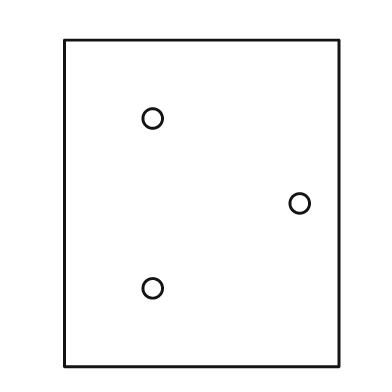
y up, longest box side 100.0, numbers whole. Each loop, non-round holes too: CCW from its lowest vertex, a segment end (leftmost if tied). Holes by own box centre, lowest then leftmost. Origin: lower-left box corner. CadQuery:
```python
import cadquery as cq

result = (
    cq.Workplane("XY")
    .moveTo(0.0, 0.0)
    .lineTo(84.0, 0.0)
    .lineTo(84.0, 100.0)
    .lineTo(0.0, 100.0)
    .close()
    .moveTo(27.0, 24.0)
    .circle(3.0)
    .moveTo(72.0, 50.0)
    .circle(3.0)
    .moveTo(27.0, 76.0)
    .circle(3.0)
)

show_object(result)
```